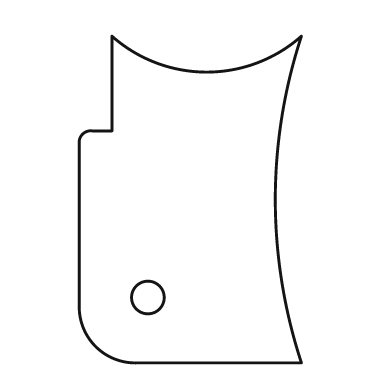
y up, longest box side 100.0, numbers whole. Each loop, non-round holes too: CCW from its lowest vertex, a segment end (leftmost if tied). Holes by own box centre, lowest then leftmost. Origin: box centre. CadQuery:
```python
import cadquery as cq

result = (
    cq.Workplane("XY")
    .moveTo(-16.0, -50.0)
    .lineTo(34.0, -50.0)
    .threePointArc((26.0, 0.0), (34.0, 50.0))
    .threePointArc((5.0, 39.0), (-24.0, 50.0))
    .lineTo(-24.0, 21.0)
    .lineTo(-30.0, 21.0)
    .threePointArc((-33.0, 20.0), (-34.0, 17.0))
    .lineTo(-34.0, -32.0)
    .threePointArc((-29.0, -45.0), (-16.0, -50.0))
    .close()
    .moveTo(-13.0, -30.0)
    .circle(5.0)
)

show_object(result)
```